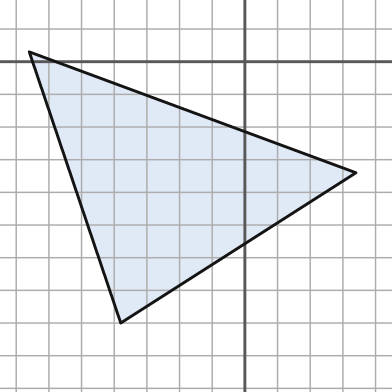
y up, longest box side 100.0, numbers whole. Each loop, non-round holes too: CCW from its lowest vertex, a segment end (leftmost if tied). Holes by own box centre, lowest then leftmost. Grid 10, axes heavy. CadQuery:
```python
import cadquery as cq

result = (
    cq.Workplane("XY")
    .moveTo(-38.0, -80.0)
    .lineTo(34.0, -34.0)
    .lineTo(-66.0, 3.0)
    .close()
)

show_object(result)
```